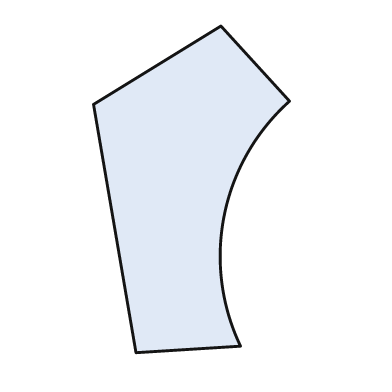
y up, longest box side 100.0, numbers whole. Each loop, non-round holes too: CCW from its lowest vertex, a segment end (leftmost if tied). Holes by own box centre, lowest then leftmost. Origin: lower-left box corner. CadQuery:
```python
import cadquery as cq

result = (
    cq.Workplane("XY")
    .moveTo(13.0, 0.0)
    .lineTo(45.0, 2.0)
    .threePointArc((40.0, 42.0), (60.0, 77.0))
    .lineTo(39.0, 100.0)
    .lineTo(0.0, 76.0)
    .close()
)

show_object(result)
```